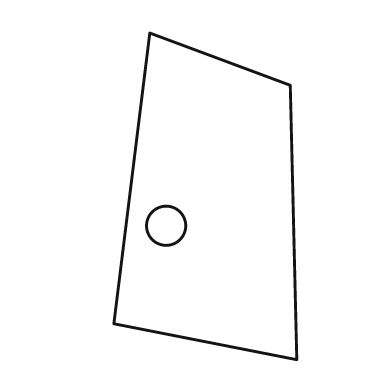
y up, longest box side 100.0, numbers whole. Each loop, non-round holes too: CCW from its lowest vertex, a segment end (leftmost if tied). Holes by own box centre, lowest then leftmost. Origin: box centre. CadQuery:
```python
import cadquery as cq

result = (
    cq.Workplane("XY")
    .moveTo(28.0, -50.0)
    .lineTo(26.0, 34.0)
    .lineTo(-17.0, 50.0)
    .lineTo(-28.0, -39.0)
    .close()
    .moveTo(-12.0, -9.0)
    .circle(6.0)
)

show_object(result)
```